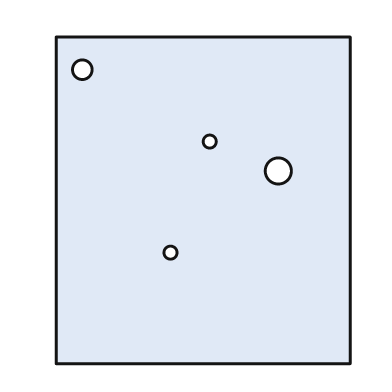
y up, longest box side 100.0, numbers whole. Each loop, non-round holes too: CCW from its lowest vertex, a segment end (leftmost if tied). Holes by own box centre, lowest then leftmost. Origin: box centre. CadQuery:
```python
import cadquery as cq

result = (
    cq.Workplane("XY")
    .moveTo(-45.0, -50.0)
    .lineTo(45.0, -50.0)
    .lineTo(45.0, 50.0)
    .lineTo(-45.0, 50.0)
    .close()
    .moveTo(-10.0, -16.0)
    .circle(2.0)
    .moveTo(23.0, 9.0)
    .circle(4.0)
    .moveTo(2.0, 18.0)
    .circle(2.0)
    .moveTo(-37.0, 40.0)
    .circle(3.0)
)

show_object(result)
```